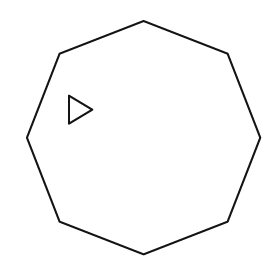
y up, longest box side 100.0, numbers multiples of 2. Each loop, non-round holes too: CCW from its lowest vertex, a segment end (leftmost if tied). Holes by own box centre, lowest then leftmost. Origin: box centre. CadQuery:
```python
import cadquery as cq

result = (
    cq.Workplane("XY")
    .moveTo(0.0, -50.0)
    .lineTo(36.0, -36.0)
    .lineTo(50.0, 0.0)
    .lineTo(36.0, 36.0)
    .lineTo(0.0, 50.0)
    .lineTo(-36.0, 36.0)
    .lineTo(-50.0, 0.0)
    .lineTo(-36.0, -36.0)
    .close()
    .moveTo(-32.0, 6.0)
    .lineTo(-22.0, 12.0)
    .lineTo(-32.0, 18.0)
    .close()
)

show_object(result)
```